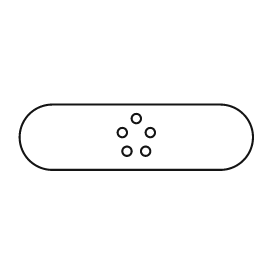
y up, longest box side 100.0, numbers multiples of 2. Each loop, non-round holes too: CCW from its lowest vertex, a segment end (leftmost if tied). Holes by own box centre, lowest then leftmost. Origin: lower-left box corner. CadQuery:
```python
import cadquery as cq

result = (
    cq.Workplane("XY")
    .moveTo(14.0, 0.0)
    .lineTo(86.0, 0.0)
    .threePointArc((100.0, 14.0), (86.0, 28.0))
    .lineTo(14.0, 28.0)
    .threePointArc((0.0, 14.0), (14.0, 0.0))
    .close()
    .moveTo(46.0, 8.0)
    .circle(2.0)
    .moveTo(54.0, 8.0)
    .circle(2.0)
    .moveTo(44.0, 16.0)
    .circle(2.0)
    .moveTo(56.0, 16.0)
    .circle(2.0)
    .moveTo(50.0, 22.0)
    .circle(2.0)
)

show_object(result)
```